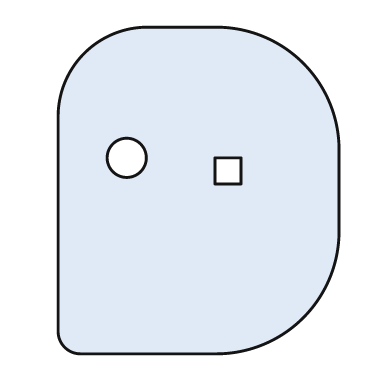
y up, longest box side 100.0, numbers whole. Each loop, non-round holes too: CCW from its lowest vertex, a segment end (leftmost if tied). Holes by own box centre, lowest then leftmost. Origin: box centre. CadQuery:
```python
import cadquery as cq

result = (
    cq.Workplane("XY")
    .moveTo(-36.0, -50.0)
    .lineTo(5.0, -50.0)
    .threePointArc((32.0, -39.0), (43.0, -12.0))
    .lineTo(43.0, 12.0)
    .threePointArc((32.0, 39.0), (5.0, 50.0))
    .lineTo(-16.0, 50.0)
    .threePointArc((-35.0, 42.0), (-43.0, 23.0))
    .lineTo(-43.0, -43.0)
    .threePointArc((-41.0, -48.0), (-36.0, -50.0))
    .close()
    .moveTo(5.0, 2.0)
    .lineTo(13.0, 2.0)
    .lineTo(13.0, 10.0)
    .lineTo(5.0, 10.0)
    .close()
    .moveTo(-22.0, 10.0)
    .circle(6.0)
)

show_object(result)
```